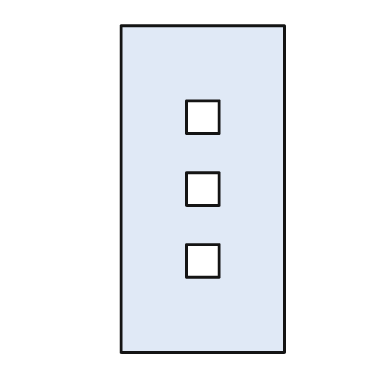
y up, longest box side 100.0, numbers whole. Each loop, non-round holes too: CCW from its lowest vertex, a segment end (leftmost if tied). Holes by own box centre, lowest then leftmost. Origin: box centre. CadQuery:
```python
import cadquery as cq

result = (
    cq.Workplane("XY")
    .moveTo(-25.0, -50.0)
    .lineTo(25.0, -50.0)
    .lineTo(25.0, 50.0)
    .lineTo(-25.0, 50.0)
    .close()
    .moveTo(-5.0, -27.0)
    .lineTo(5.0, -27.0)
    .lineTo(5.0, -17.0)
    .lineTo(-5.0, -17.0)
    .close()
    .moveTo(-5.0, -5.0)
    .lineTo(5.0, -5.0)
    .lineTo(5.0, 5.0)
    .lineTo(-5.0, 5.0)
    .close()
    .moveTo(-5.0, 17.0)
    .lineTo(5.0, 17.0)
    .lineTo(5.0, 27.0)
    .lineTo(-5.0, 27.0)
    .close()
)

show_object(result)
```